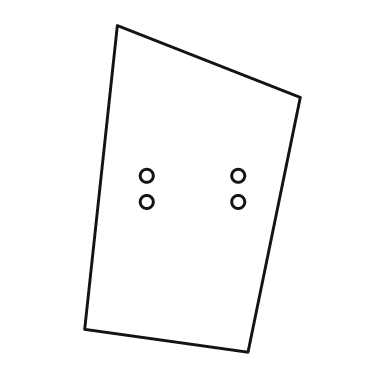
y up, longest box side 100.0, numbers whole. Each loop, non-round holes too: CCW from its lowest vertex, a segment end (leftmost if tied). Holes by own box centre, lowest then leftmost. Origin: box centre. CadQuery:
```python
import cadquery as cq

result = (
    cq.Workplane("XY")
    .moveTo(17.0, -50.0)
    .lineTo(33.0, 28.0)
    .lineTo(-23.0, 50.0)
    .lineTo(-33.0, -43.0)
    .close()
    .moveTo(-14.0, -4.0)
    .circle(2.0)
    .moveTo(14.0, -4.0)
    .circle(2.0)
    .moveTo(-14.0, 4.0)
    .circle(2.0)
    .moveTo(14.0, 4.0)
    .circle(2.0)
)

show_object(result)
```